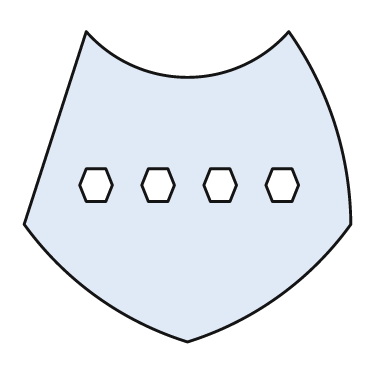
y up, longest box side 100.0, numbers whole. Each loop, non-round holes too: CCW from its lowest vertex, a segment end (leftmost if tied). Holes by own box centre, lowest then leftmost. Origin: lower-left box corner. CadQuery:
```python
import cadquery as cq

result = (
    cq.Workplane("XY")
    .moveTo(50.0, 0.0)
    .threePointArc((78.0, 14.0), (100.0, 36.0))
    .threePointArc((95.0, 67.0), (81.0, 95.0))
    .threePointArc((50.0, 81.0), (19.0, 95.0))
    .lineTo(0.0, 36.0)
    .threePointArc((22.0, 14.0), (50.0, 0.0))
    .close()
    .moveTo(19.0, 43.0)
    .lineTo(25.0, 43.0)
    .lineTo(27.0, 48.0)
    .lineTo(25.0, 53.0)
    .lineTo(19.0, 53.0)
    .lineTo(17.0, 48.0)
    .close()
    .moveTo(38.0, 43.0)
    .lineTo(44.0, 43.0)
    .lineTo(46.0, 48.0)
    .lineTo(44.0, 53.0)
    .lineTo(38.0, 53.0)
    .lineTo(36.0, 48.0)
    .close()
    .moveTo(57.0, 43.0)
    .lineTo(63.0, 43.0)
    .lineTo(65.0, 48.0)
    .lineTo(63.0, 53.0)
    .lineTo(57.0, 53.0)
    .lineTo(55.0, 48.0)
    .close()
    .moveTo(76.0, 43.0)
    .lineTo(82.0, 43.0)
    .lineTo(84.0, 48.0)
    .lineTo(82.0, 53.0)
    .lineTo(76.0, 53.0)
    .lineTo(74.0, 48.0)
    .close()
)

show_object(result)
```